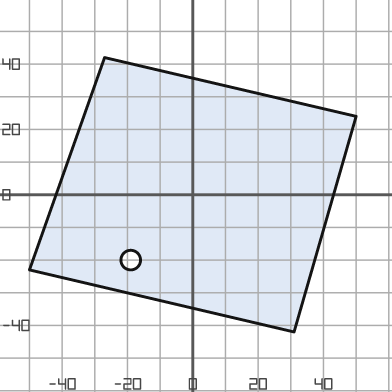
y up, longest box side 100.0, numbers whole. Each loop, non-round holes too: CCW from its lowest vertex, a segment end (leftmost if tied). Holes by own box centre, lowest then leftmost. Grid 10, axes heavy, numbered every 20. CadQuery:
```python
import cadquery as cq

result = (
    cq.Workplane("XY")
    .moveTo(31.0, -42.0)
    .lineTo(50.0, 24.0)
    .lineTo(-27.0, 42.0)
    .lineTo(-50.0, -23.0)
    .close()
    .moveTo(-19.0, -20.0)
    .circle(3.0)
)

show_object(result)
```